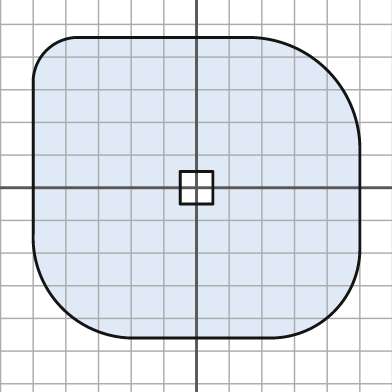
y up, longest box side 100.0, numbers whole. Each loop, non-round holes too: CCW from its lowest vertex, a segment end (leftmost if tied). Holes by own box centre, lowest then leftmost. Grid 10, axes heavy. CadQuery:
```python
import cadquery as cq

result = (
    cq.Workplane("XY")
    .moveTo(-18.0, -46.0)
    .lineTo(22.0, -46.0)
    .threePointArc((42.0, -38.0), (50.0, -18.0))
    .lineTo(50.0, 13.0)
    .threePointArc((40.0, 36.0), (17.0, 46.0))
    .lineTo(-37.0, 46.0)
    .threePointArc((-46.0, 42.0), (-50.0, 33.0))
    .lineTo(-50.0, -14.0)
    .threePointArc((-41.0, -37.0), (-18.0, -46.0))
    .close()
    .moveTo(-5.0, -5.0)
    .lineTo(5.0, -5.0)
    .lineTo(5.0, 5.0)
    .lineTo(-5.0, 5.0)
    .close()
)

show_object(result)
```